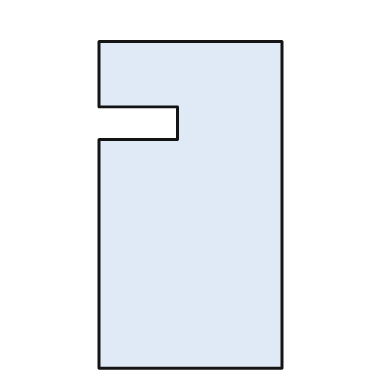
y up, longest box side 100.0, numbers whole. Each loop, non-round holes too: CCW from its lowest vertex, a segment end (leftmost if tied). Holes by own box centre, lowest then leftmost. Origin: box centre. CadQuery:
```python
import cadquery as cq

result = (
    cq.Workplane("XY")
    .moveTo(-28.0, -50.0)
    .lineTo(28.0, -50.0)
    .lineTo(28.0, 50.0)
    .lineTo(-28.0, 50.0)
    .lineTo(-28.0, 30.0)
    .lineTo(-4.0, 30.0)
    .lineTo(-4.0, 20.0)
    .lineTo(-28.0, 20.0)
    .close()
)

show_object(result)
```